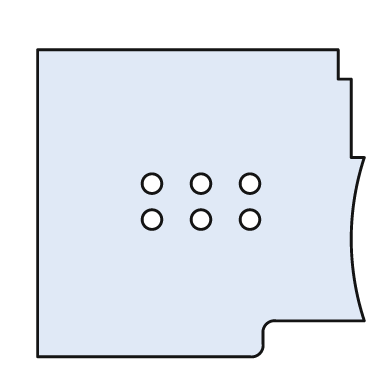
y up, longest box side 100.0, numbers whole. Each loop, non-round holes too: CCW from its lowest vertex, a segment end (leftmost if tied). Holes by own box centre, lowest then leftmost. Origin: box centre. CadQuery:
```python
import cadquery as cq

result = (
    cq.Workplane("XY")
    .moveTo(-50.0, -47.0)
    .lineTo(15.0, -47.0)
    .threePointArc((18.0, -46.0), (19.0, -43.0))
    .lineTo(19.0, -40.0)
    .threePointArc((20.0, -37.0), (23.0, -36.0))
    .lineTo(50.0, -36.0)
    .threePointArc((46.0, -11.0), (50.0, 14.0))
    .lineTo(46.0, 14.0)
    .lineTo(46.0, 38.0)
    .lineTo(42.0, 38.0)
    .lineTo(42.0, 47.0)
    .lineTo(-50.0, 47.0)
    .close()
    .moveTo(-15.0, -5.0)
    .circle(3.0)
    .moveTo(0.0, -5.0)
    .circle(3.0)
    .moveTo(15.0, -5.0)
    .circle(3.0)
    .moveTo(-15.0, 6.0)
    .circle(3.0)
    .moveTo(0.0, 6.0)
    .circle(3.0)
    .moveTo(15.0, 6.0)
    .circle(3.0)
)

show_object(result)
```